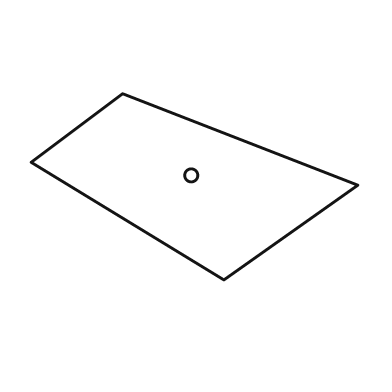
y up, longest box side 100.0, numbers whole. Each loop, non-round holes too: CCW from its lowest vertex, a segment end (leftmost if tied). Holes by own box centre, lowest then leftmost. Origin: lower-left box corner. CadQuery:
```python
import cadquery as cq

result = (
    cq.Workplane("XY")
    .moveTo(59.0, 0.0)
    .lineTo(100.0, 29.0)
    .lineTo(28.0, 57.0)
    .lineTo(0.0, 36.0)
    .close()
    .moveTo(49.0, 32.0)
    .circle(2.0)
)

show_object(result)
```